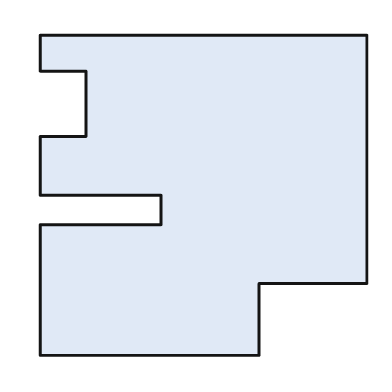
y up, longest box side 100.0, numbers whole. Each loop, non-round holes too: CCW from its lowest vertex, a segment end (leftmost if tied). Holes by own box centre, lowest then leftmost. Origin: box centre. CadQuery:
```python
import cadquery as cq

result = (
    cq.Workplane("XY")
    .moveTo(-50.0, -49.0)
    .lineTo(17.0, -49.0)
    .lineTo(17.0, -27.0)
    .lineTo(50.0, -27.0)
    .lineTo(50.0, 49.0)
    .lineTo(-50.0, 49.0)
    .lineTo(-50.0, 38.0)
    .lineTo(-36.0, 38.0)
    .lineTo(-36.0, 18.0)
    .lineTo(-50.0, 18.0)
    .lineTo(-50.0, 0.0)
    .lineTo(-13.0, 0.0)
    .lineTo(-13.0, -9.0)
    .lineTo(-50.0, -9.0)
    .close()
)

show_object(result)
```